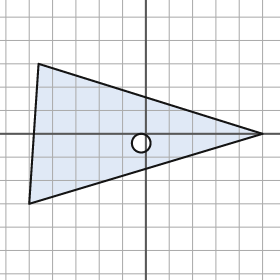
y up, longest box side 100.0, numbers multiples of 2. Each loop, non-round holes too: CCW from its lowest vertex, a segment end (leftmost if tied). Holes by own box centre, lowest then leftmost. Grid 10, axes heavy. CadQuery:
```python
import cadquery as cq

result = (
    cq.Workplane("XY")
    .moveTo(-50.0, -30.0)
    .lineTo(50.0, 0.0)
    .lineTo(-46.0, 30.0)
    .close()
    .moveTo(-2.0, -4.0)
    .circle(4.0)
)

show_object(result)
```